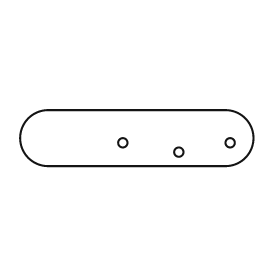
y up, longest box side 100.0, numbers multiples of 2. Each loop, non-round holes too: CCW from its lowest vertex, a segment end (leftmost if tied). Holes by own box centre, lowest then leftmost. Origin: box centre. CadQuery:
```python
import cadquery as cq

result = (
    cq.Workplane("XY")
    .moveTo(-38.0, -12.0)
    .lineTo(38.0, -12.0)
    .threePointArc((50.0, 0.0), (38.0, 12.0))
    .lineTo(-38.0, 12.0)
    .threePointArc((-50.0, 0.0), (-38.0, -12.0))
    .close()
    .moveTo(18.0, -6.0)
    .circle(2.0)
    .moveTo(-6.0, -2.0)
    .circle(2.0)
    .moveTo(40.0, -2.0)
    .circle(2.0)
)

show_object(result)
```